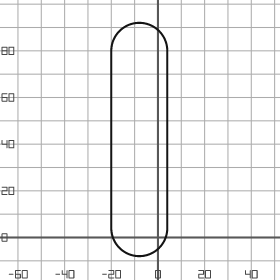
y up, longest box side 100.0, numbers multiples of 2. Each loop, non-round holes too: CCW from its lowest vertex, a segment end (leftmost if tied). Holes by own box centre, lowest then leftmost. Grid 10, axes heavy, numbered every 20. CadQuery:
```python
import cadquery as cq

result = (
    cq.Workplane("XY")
    .moveTo(-20.0, 4.0)
    .threePointArc((-8.0, -8.0), (4.0, 4.0))
    .lineTo(4.0, 80.0)
    .threePointArc((-8.0, 92.0), (-20.0, 80.0))
    .close()
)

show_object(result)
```